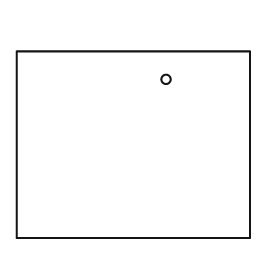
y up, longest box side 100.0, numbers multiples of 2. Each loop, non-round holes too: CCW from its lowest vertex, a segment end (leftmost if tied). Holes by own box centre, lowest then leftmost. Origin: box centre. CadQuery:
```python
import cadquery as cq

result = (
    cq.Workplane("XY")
    .moveTo(-50.0, -40.0)
    .lineTo(50.0, -40.0)
    .lineTo(50.0, 40.0)
    .lineTo(-50.0, 40.0)
    .close()
    .moveTo(14.0, 28.0)
    .circle(2.0)
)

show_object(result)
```